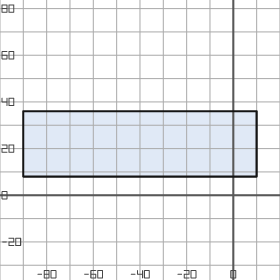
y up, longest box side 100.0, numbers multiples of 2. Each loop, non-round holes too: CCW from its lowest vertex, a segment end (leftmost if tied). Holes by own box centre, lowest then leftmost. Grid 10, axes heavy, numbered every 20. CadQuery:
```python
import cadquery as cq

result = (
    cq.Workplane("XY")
    .moveTo(-90.0, 8.0)
    .lineTo(10.0, 8.0)
    .lineTo(10.0, 36.0)
    .lineTo(-90.0, 36.0)
    .close()
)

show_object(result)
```